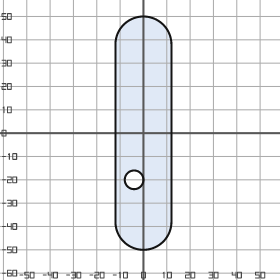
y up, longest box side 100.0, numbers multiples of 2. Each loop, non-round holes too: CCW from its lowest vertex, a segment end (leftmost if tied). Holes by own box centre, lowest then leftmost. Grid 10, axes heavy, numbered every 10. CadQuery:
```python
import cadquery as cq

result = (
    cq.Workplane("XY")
    .moveTo(-12.0, -38.0)
    .threePointArc((0.0, -50.0), (12.0, -38.0))
    .lineTo(12.0, 38.0)
    .threePointArc((0.0, 50.0), (-12.0, 38.0))
    .close()
    .moveTo(-4.0, -20.0)
    .circle(4.0)
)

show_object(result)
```